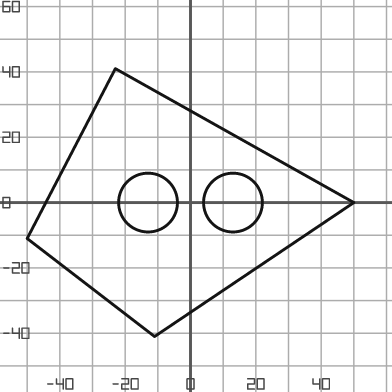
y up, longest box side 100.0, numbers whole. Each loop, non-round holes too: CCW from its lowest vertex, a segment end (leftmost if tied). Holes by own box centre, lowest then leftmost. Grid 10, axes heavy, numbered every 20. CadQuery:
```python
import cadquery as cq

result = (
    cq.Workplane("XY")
    .moveTo(-11.0, -41.0)
    .lineTo(50.0, 0.0)
    .lineTo(-23.0, 41.0)
    .lineTo(-50.0, -11.0)
    .close()
    .moveTo(-13.0, 0.0)
    .circle(9.0)
    .moveTo(13.0, 0.0)
    .circle(9.0)
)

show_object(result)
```